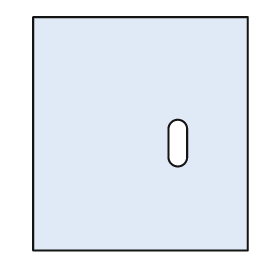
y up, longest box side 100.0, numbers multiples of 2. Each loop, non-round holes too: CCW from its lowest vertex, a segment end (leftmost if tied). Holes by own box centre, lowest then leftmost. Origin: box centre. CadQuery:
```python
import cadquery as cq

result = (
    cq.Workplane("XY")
    .moveTo(-46.0, -50.0)
    .lineTo(46.0, -50.0)
    .lineTo(46.0, 50.0)
    .lineTo(-46.0, 50.0)
    .close()
    .moveTo(12.0, -10.0)
    .threePointArc((16.0, -14.0), (20.0, -10.0))
    .lineTo(20.0, 2.0)
    .threePointArc((16.0, 6.0), (12.0, 2.0))
    .close()
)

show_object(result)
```